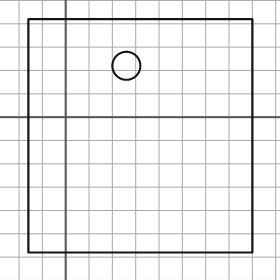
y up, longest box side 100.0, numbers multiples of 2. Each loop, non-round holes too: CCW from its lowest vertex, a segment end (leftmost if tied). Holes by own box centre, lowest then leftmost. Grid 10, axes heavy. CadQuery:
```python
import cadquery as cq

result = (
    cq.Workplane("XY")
    .moveTo(-16.0, -58.0)
    .lineTo(80.0, -58.0)
    .lineTo(80.0, 42.0)
    .lineTo(-16.0, 42.0)
    .close()
    .moveTo(26.0, 22.0)
    .circle(6.0)
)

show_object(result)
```